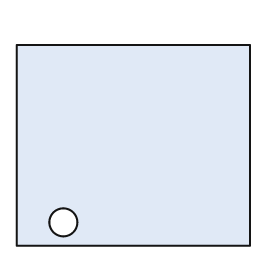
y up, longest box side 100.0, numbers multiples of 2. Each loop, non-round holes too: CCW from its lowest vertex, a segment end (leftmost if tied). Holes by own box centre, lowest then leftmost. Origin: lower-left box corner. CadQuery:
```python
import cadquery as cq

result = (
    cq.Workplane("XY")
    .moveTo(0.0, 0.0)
    .lineTo(100.0, 0.0)
    .lineTo(100.0, 86.0)
    .lineTo(0.0, 86.0)
    .close()
    .moveTo(20.0, 10.0)
    .circle(6.0)
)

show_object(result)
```